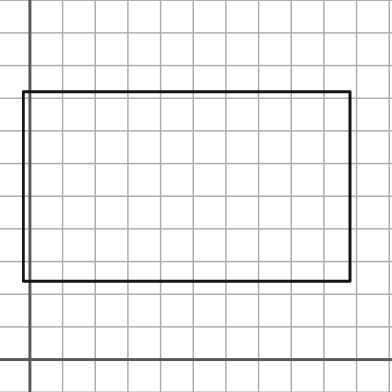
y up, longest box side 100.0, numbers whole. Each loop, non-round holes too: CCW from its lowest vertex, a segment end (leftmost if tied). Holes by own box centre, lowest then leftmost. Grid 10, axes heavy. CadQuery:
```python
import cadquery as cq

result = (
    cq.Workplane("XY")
    .moveTo(-2.0, 24.0)
    .lineTo(98.0, 24.0)
    .lineTo(98.0, 82.0)
    .lineTo(-2.0, 82.0)
    .close()
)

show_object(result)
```